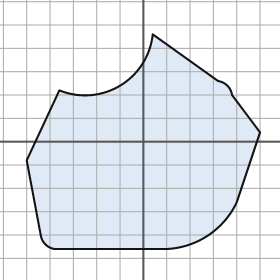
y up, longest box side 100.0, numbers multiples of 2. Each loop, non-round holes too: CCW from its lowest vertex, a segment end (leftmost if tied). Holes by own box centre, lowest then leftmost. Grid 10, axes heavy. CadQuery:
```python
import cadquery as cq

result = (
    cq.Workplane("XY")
    .moveTo(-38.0, -46.0)
    .lineTo(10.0, -46.0)
    .threePointArc((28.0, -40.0), (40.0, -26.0))
    .lineTo(50.0, 4.0)
    .lineTo(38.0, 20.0)
    .threePointArc((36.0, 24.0), (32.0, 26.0))
    .lineTo(4.0, 46.0)
    .threePointArc((-10.0, 24.0), (-36.0, 22.0))
    .lineTo(-50.0, -8.0)
    .lineTo(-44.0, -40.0)
    .threePointArc((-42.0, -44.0), (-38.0, -46.0))
    .close()
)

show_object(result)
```